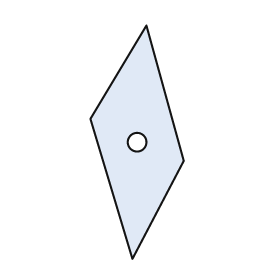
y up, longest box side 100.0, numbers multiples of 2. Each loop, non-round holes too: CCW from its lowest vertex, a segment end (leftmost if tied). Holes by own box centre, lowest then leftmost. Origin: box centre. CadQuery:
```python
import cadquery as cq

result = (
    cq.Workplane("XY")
    .moveTo(-2.0, -50.0)
    .lineTo(20.0, -8.0)
    .lineTo(4.0, 50.0)
    .lineTo(-20.0, 10.0)
    .close()
    .moveTo(0.0, 0.0)
    .circle(4.0)
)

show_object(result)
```